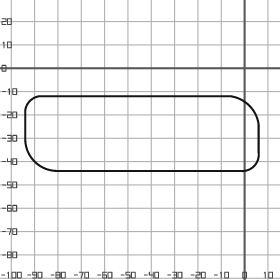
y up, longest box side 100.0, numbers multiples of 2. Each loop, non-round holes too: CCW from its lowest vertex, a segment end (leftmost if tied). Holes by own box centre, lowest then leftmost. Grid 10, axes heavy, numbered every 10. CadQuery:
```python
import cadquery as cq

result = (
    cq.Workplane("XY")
    .moveTo(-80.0, -44.0)
    .lineTo(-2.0, -44.0)
    .threePointArc((4.0, -42.0), (6.0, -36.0))
    .lineTo(6.0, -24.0)
    .threePointArc((2.0, -16.0), (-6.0, -12.0))
    .lineTo(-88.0, -12.0)
    .threePointArc((-92.0, -14.0), (-94.0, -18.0))
    .lineTo(-94.0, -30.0)
    .threePointArc((-90.0, -40.0), (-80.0, -44.0))
    .close()
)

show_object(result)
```